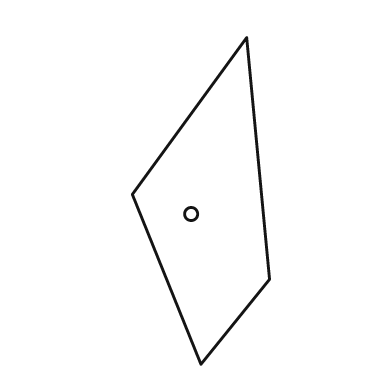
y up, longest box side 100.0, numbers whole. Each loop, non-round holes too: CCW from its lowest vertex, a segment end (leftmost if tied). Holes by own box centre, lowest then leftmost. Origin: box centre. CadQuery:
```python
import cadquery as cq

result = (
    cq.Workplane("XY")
    .moveTo(0.0, -50.0)
    .lineTo(21.0, -24.0)
    .lineTo(14.0, 50.0)
    .lineTo(-21.0, 2.0)
    .close()
    .moveTo(-3.0, -4.0)
    .circle(2.0)
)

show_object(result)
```